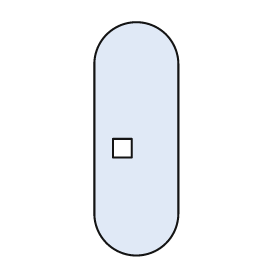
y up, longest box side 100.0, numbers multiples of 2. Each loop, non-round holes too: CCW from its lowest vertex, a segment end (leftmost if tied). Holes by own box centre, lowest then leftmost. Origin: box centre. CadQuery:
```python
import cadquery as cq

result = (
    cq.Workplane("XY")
    .moveTo(-18.0, -32.0)
    .threePointArc((0.0, -50.0), (18.0, -32.0))
    .lineTo(18.0, 32.0)
    .threePointArc((0.0, 50.0), (-18.0, 32.0))
    .close()
    .moveTo(-10.0, -8.0)
    .lineTo(-2.0, -8.0)
    .lineTo(-2.0, 0.0)
    .lineTo(-10.0, 0.0)
    .close()
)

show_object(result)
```